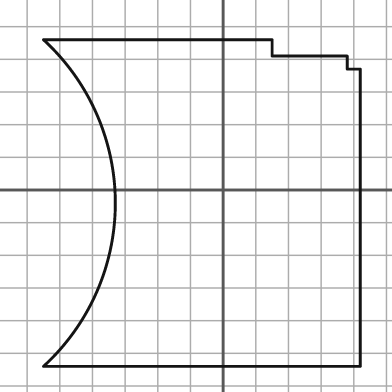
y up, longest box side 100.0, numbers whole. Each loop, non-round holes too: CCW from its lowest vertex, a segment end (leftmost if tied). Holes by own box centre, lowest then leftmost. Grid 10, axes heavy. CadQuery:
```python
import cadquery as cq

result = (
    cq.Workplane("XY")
    .moveTo(-55.0, -54.0)
    .lineTo(42.0, -54.0)
    .lineTo(42.0, 37.0)
    .lineTo(38.0, 37.0)
    .lineTo(38.0, 41.0)
    .lineTo(15.0, 41.0)
    .lineTo(15.0, 46.0)
    .lineTo(-55.0, 46.0)
    .threePointArc((-33.0, -4.0), (-55.0, -54.0))
    .close()
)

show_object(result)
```